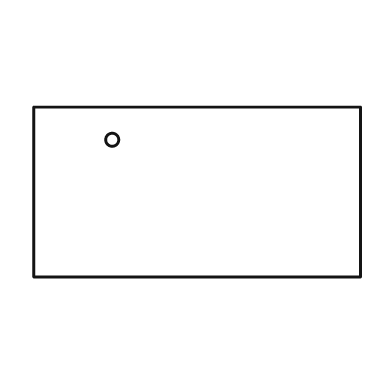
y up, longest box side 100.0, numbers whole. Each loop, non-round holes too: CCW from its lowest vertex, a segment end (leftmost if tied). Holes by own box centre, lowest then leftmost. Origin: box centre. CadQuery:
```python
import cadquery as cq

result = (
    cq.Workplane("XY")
    .moveTo(-50.0, -26.0)
    .lineTo(50.0, -26.0)
    .lineTo(50.0, 26.0)
    .lineTo(-50.0, 26.0)
    .close()
    .moveTo(-26.0, 16.0)
    .circle(2.0)
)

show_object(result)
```